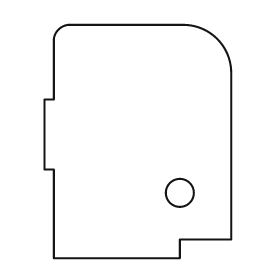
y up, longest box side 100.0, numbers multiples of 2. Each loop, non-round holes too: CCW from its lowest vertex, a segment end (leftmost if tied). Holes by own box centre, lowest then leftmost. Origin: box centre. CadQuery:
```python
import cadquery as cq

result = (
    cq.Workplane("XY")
    .moveTo(-36.0, -50.0)
    .lineTo(18.0, -50.0)
    .lineTo(18.0, -42.0)
    .lineTo(40.0, -42.0)
    .lineTo(40.0, 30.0)
    .threePointArc((34.0, 44.0), (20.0, 50.0))
    .lineTo(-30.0, 50.0)
    .threePointArc((-34.0, 48.0), (-36.0, 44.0))
    .lineTo(-36.0, 18.0)
    .lineTo(-40.0, 18.0)
    .lineTo(-40.0, -12.0)
    .lineTo(-36.0, -12.0)
    .close()
    .moveTo(18.0, -22.0)
    .circle(6.0)
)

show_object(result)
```